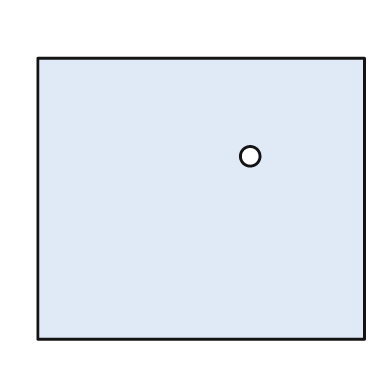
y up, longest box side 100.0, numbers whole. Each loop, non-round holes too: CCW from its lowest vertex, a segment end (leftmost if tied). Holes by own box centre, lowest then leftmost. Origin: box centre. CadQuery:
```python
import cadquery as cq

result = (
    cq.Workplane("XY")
    .moveTo(-50.0, -43.0)
    .lineTo(50.0, -43.0)
    .lineTo(50.0, 43.0)
    .lineTo(-50.0, 43.0)
    .close()
    .moveTo(15.0, 13.0)
    .circle(3.0)
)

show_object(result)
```